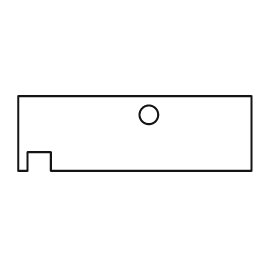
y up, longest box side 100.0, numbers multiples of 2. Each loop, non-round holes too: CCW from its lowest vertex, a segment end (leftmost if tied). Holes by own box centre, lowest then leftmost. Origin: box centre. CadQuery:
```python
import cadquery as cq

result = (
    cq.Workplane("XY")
    .moveTo(-50.0, -16.0)
    .lineTo(-46.0, -16.0)
    .lineTo(-46.0, -8.0)
    .lineTo(-36.0, -8.0)
    .lineTo(-36.0, -16.0)
    .lineTo(50.0, -16.0)
    .lineTo(50.0, 16.0)
    .lineTo(-50.0, 16.0)
    .close()
    .moveTo(6.0, 8.0)
    .circle(4.0)
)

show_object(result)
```